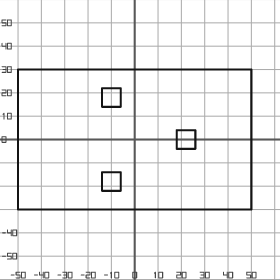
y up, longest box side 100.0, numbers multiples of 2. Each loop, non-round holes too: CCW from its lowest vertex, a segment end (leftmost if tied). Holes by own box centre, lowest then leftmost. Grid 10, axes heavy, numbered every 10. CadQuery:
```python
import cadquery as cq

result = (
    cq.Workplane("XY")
    .moveTo(-50.0, -30.0)
    .lineTo(50.0, -30.0)
    .lineTo(50.0, 30.0)
    .lineTo(-50.0, 30.0)
    .close()
    .moveTo(-14.0, -22.0)
    .lineTo(-6.0, -22.0)
    .lineTo(-6.0, -14.0)
    .lineTo(-14.0, -14.0)
    .close()
    .moveTo(18.0, -4.0)
    .lineTo(26.0, -4.0)
    .lineTo(26.0, 4.0)
    .lineTo(18.0, 4.0)
    .close()
    .moveTo(-14.0, 14.0)
    .lineTo(-6.0, 14.0)
    .lineTo(-6.0, 22.0)
    .lineTo(-14.0, 22.0)
    .close()
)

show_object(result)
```